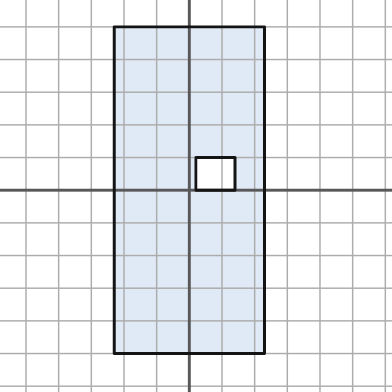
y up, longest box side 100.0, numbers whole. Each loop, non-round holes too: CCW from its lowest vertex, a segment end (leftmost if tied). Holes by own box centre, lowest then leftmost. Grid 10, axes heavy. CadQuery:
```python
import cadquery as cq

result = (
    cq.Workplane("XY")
    .moveTo(-23.0, -50.0)
    .lineTo(23.0, -50.0)
    .lineTo(23.0, 50.0)
    .lineTo(-23.0, 50.0)
    .close()
    .moveTo(2.0, 0.0)
    .lineTo(14.0, 0.0)
    .lineTo(14.0, 10.0)
    .lineTo(2.0, 10.0)
    .close()
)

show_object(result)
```